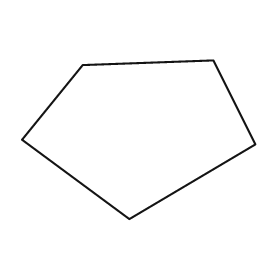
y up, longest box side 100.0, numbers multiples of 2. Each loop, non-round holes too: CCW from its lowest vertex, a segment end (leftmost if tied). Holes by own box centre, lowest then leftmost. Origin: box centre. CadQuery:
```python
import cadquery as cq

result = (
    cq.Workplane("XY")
    .moveTo(-4.0, -34.0)
    .lineTo(50.0, -2.0)
    .lineTo(32.0, 34.0)
    .lineTo(-24.0, 32.0)
    .lineTo(-50.0, 0.0)
    .close()
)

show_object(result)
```